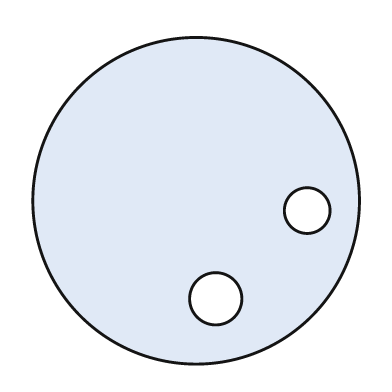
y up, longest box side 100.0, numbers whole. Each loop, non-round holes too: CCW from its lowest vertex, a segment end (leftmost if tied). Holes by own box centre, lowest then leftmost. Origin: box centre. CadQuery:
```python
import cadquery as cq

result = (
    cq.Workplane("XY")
    .moveTo(0.0, 0.0)
    .circle(50.0)
    .moveTo(6.0, -30.0)
    .circle(8.0)
    .moveTo(34.0, -3.0)
    .circle(7.0)
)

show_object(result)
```